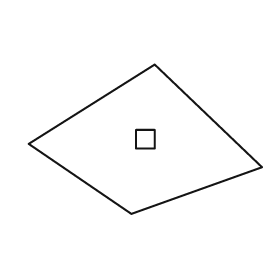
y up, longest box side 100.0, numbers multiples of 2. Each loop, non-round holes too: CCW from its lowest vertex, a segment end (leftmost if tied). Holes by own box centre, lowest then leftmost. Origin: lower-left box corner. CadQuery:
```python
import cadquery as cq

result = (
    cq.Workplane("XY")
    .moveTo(44.0, 0.0)
    .lineTo(100.0, 20.0)
    .lineTo(54.0, 64.0)
    .lineTo(0.0, 30.0)
    .close()
    .moveTo(46.0, 28.0)
    .lineTo(54.0, 28.0)
    .lineTo(54.0, 36.0)
    .lineTo(46.0, 36.0)
    .close()
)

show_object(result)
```